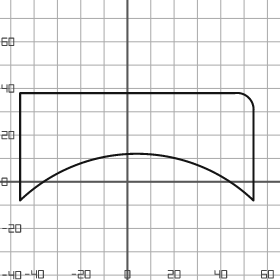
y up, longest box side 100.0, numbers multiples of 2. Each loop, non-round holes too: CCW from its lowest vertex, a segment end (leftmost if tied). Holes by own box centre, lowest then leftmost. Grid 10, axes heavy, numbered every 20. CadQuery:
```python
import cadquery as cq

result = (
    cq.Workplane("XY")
    .moveTo(-46.0, -8.0)
    .threePointArc((4.0, 12.0), (54.0, -8.0))
    .lineTo(54.0, 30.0)
    .threePointArc((52.0, 36.0), (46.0, 38.0))
    .lineTo(-46.0, 38.0)
    .close()
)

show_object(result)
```